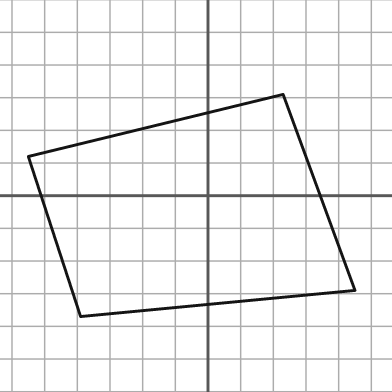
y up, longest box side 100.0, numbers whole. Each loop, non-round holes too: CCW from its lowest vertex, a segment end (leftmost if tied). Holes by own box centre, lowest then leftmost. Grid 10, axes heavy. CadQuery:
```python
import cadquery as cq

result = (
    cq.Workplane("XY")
    .moveTo(-39.0, -37.0)
    .lineTo(45.0, -29.0)
    .lineTo(23.0, 31.0)
    .lineTo(-55.0, 12.0)
    .close()
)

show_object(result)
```